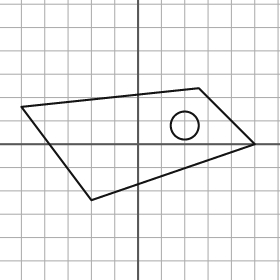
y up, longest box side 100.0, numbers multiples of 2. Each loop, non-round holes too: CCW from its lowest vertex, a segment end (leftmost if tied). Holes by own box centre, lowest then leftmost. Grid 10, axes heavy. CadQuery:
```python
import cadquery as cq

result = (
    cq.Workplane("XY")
    .moveTo(-20.0, -24.0)
    .lineTo(50.0, 0.0)
    .lineTo(26.0, 24.0)
    .lineTo(-50.0, 16.0)
    .close()
    .moveTo(20.0, 8.0)
    .circle(6.0)
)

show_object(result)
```